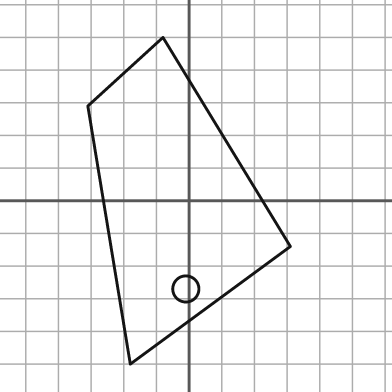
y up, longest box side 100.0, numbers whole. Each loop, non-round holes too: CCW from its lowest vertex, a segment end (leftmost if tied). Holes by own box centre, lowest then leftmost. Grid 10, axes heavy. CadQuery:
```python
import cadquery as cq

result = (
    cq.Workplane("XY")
    .moveTo(-18.0, -50.0)
    .lineTo(31.0, -14.0)
    .lineTo(-8.0, 50.0)
    .lineTo(-31.0, 29.0)
    .close()
    .moveTo(-1.0, -27.0)
    .circle(4.0)
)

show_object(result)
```